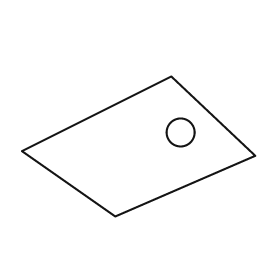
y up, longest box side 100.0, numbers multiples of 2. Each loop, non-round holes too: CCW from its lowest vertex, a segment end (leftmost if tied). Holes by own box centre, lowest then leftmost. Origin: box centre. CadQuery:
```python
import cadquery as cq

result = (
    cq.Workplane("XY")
    .moveTo(-10.0, -30.0)
    .lineTo(50.0, -4.0)
    .lineTo(14.0, 30.0)
    .lineTo(-50.0, -2.0)
    .close()
    .moveTo(18.0, 6.0)
    .circle(6.0)
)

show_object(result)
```